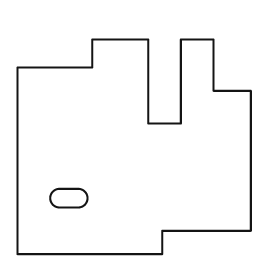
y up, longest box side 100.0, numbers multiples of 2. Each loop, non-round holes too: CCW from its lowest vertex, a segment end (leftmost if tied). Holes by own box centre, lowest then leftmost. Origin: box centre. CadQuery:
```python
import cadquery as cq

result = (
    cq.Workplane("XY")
    .moveTo(-50.0, -46.0)
    .lineTo(12.0, -46.0)
    .lineTo(12.0, -36.0)
    .lineTo(50.0, -36.0)
    .lineTo(50.0, 24.0)
    .lineTo(34.0, 24.0)
    .lineTo(34.0, 46.0)
    .lineTo(20.0, 46.0)
    .lineTo(20.0, 10.0)
    .lineTo(6.0, 10.0)
    .lineTo(6.0, 46.0)
    .lineTo(-18.0, 46.0)
    .lineTo(-18.0, 34.0)
    .lineTo(-50.0, 34.0)
    .close()
    .moveTo(-32.0, -26.0)
    .lineTo(-24.0, -26.0)
    .threePointArc((-20.0, -22.0), (-24.0, -18.0))
    .lineTo(-32.0, -18.0)
    .threePointArc((-36.0, -22.0), (-32.0, -26.0))
    .close()
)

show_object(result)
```